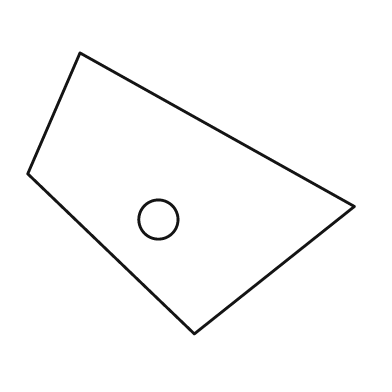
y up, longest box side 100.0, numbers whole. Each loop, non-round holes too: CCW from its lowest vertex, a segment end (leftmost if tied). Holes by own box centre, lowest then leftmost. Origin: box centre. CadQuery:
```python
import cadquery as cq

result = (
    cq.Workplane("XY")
    .moveTo(1.0, -43.0)
    .lineTo(50.0, -4.0)
    .lineTo(-34.0, 43.0)
    .lineTo(-50.0, 6.0)
    .close()
    .moveTo(-10.0, -8.0)
    .circle(6.0)
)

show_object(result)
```